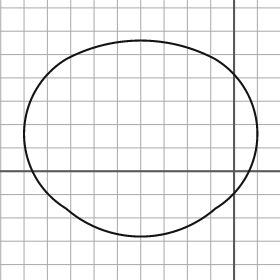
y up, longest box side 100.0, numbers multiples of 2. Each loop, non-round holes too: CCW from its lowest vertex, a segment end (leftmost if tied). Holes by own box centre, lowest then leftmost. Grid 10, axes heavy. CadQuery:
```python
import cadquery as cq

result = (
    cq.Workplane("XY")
    .moveTo(-72.0, -16.0)
    .threePointArc((-40.0, -28.0), (-8.0, -16.0))
    .threePointArc((10.0, 16.0), (-8.0, 48.0))
    .threePointArc((-40.0, 56.0), (-72.0, 48.0))
    .threePointArc((-90.0, 16.0), (-72.0, -16.0))
    .close()
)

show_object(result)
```